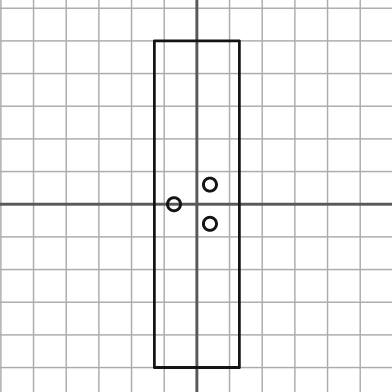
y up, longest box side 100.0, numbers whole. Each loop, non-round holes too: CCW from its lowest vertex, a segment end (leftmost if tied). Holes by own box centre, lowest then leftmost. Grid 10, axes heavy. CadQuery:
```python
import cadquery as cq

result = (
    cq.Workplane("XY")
    .moveTo(-13.0, -50.0)
    .lineTo(13.0, -50.0)
    .lineTo(13.0, 50.0)
    .lineTo(-13.0, 50.0)
    .close()
    .moveTo(4.0, -6.0)
    .circle(2.0)
    .moveTo(-7.0, 0.0)
    .circle(2.0)
    .moveTo(4.0, 6.0)
    .circle(2.0)
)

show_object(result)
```